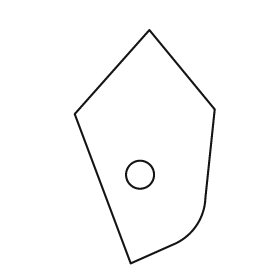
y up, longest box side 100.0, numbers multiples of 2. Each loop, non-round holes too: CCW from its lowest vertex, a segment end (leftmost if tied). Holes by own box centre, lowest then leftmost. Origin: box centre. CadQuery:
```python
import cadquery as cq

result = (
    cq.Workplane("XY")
    .moveTo(-6.0, -50.0)
    .lineTo(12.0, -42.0)
    .threePointArc((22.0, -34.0), (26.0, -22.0))
    .lineTo(30.0, 16.0)
    .lineTo(2.0, 50.0)
    .lineTo(-30.0, 14.0)
    .close()
    .moveTo(-2.0, -12.0)
    .circle(6.0)
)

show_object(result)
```